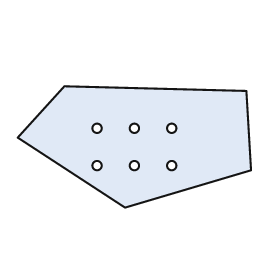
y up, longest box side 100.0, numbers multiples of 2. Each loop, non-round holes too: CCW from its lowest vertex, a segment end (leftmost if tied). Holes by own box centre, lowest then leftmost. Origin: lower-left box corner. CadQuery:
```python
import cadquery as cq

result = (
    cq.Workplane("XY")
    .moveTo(46.0, 0.0)
    .lineTo(100.0, 16.0)
    .lineTo(98.0, 50.0)
    .lineTo(20.0, 52.0)
    .lineTo(0.0, 30.0)
    .close()
    .moveTo(34.0, 18.0)
    .circle(2.0)
    .moveTo(50.0, 18.0)
    .circle(2.0)
    .moveTo(66.0, 18.0)
    .circle(2.0)
    .moveTo(34.0, 34.0)
    .circle(2.0)
    .moveTo(50.0, 34.0)
    .circle(2.0)
    .moveTo(66.0, 34.0)
    .circle(2.0)
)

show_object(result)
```